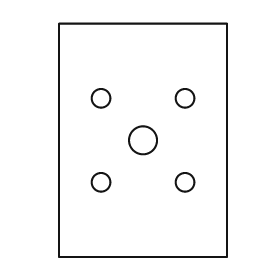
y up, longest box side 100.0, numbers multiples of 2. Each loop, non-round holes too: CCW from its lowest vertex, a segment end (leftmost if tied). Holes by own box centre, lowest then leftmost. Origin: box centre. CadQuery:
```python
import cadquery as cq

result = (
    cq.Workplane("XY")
    .moveTo(-36.0, -50.0)
    .lineTo(36.0, -50.0)
    .lineTo(36.0, 50.0)
    .lineTo(-36.0, 50.0)
    .close()
    .moveTo(-18.0, -18.0)
    .circle(4.0)
    .moveTo(18.0, -18.0)
    .circle(4.0)
    .moveTo(0.0, 0.0)
    .circle(6.0)
    .moveTo(-18.0, 18.0)
    .circle(4.0)
    .moveTo(18.0, 18.0)
    .circle(4.0)
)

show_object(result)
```